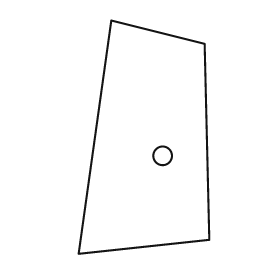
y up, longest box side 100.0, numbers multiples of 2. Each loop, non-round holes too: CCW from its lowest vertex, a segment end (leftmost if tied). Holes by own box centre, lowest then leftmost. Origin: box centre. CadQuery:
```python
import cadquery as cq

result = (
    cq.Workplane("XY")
    .moveTo(-28.0, -50.0)
    .lineTo(28.0, -44.0)
    .lineTo(26.0, 40.0)
    .lineTo(-14.0, 50.0)
    .close()
    .moveTo(8.0, -8.0)
    .circle(4.0)
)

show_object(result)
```